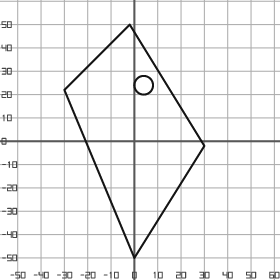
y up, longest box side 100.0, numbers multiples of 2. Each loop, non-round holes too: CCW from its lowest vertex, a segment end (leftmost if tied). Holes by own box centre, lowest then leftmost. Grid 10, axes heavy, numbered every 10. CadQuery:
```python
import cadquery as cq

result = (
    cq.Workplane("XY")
    .moveTo(0.0, -50.0)
    .lineTo(30.0, -2.0)
    .lineTo(-2.0, 50.0)
    .lineTo(-30.0, 22.0)
    .close()
    .moveTo(4.0, 24.0)
    .circle(4.0)
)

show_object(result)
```